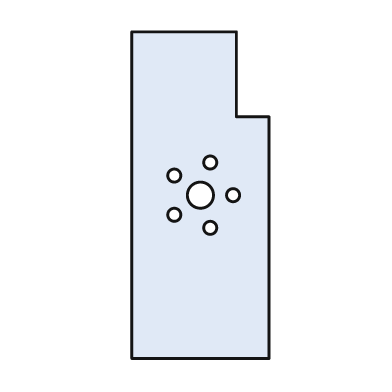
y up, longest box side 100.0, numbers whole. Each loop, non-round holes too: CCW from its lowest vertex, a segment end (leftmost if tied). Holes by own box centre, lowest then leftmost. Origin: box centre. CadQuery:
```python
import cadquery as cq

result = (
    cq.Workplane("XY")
    .moveTo(-21.0, -50.0)
    .lineTo(21.0, -50.0)
    .lineTo(21.0, 24.0)
    .lineTo(11.0, 24.0)
    .lineTo(11.0, 50.0)
    .lineTo(-21.0, 50.0)
    .close()
    .moveTo(3.0, -10.0)
    .circle(2.0)
    .moveTo(-8.0, -6.0)
    .circle(2.0)
    .moveTo(0.0, 0.0)
    .circle(4.0)
    .moveTo(10.0, 0.0)
    .circle(2.0)
    .moveTo(-8.0, 6.0)
    .circle(2.0)
    .moveTo(3.0, 10.0)
    .circle(2.0)
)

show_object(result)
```